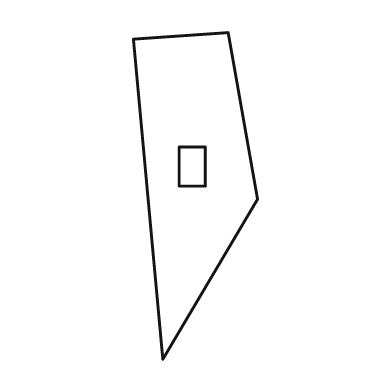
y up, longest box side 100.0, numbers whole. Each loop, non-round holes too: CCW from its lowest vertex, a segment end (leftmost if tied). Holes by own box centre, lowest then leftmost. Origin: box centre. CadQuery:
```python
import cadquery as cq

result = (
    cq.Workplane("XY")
    .moveTo(-10.0, -50.0)
    .lineTo(19.0, -1.0)
    .lineTo(10.0, 50.0)
    .lineTo(-19.0, 48.0)
    .close()
    .moveTo(-5.0, 3.0)
    .lineTo(3.0, 3.0)
    .lineTo(3.0, 15.0)
    .lineTo(-5.0, 15.0)
    .close()
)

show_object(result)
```